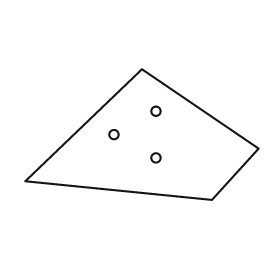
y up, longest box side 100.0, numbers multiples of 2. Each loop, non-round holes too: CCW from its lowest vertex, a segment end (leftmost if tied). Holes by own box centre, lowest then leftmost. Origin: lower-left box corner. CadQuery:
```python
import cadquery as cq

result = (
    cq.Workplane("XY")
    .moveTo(80.0, 0.0)
    .lineTo(100.0, 22.0)
    .lineTo(50.0, 56.0)
    .lineTo(0.0, 8.0)
    .close()
    .moveTo(56.0, 18.0)
    .circle(2.0)
    .moveTo(38.0, 28.0)
    .circle(2.0)
    .moveTo(56.0, 38.0)
    .circle(2.0)
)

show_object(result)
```